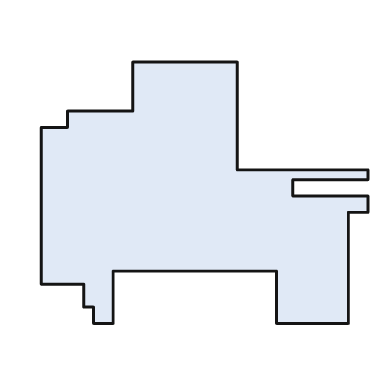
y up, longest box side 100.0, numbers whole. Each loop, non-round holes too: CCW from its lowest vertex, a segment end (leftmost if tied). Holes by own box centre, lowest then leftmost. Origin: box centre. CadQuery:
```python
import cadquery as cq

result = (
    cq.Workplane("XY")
    .moveTo(-34.0, -40.0)
    .lineTo(-28.0, -40.0)
    .lineTo(-28.0, -24.0)
    .lineTo(22.0, -24.0)
    .lineTo(22.0, -40.0)
    .lineTo(44.0, -40.0)
    .lineTo(44.0, -6.0)
    .lineTo(50.0, -6.0)
    .lineTo(50.0, -1.0)
    .lineTo(27.0, -1.0)
    .lineTo(27.0, 4.0)
    .lineTo(50.0, 4.0)
    .lineTo(50.0, 7.0)
    .lineTo(10.0, 7.0)
    .lineTo(10.0, 40.0)
    .lineTo(-22.0, 40.0)
    .lineTo(-22.0, 25.0)
    .lineTo(-42.0, 25.0)
    .lineTo(-42.0, 20.0)
    .lineTo(-50.0, 20.0)
    .lineTo(-50.0, -28.0)
    .lineTo(-37.0, -28.0)
    .lineTo(-37.0, -35.0)
    .lineTo(-34.0, -35.0)
    .close()
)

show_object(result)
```